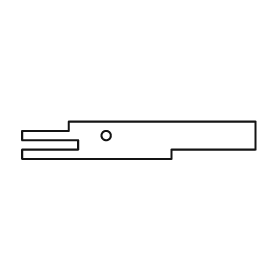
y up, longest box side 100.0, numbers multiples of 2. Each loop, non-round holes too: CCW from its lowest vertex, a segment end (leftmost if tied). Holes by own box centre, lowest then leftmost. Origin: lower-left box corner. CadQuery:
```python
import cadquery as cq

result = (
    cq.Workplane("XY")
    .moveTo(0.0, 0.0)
    .lineTo(64.0, 0.0)
    .lineTo(64.0, 4.0)
    .lineTo(100.0, 4.0)
    .lineTo(100.0, 16.0)
    .lineTo(20.0, 16.0)
    .lineTo(20.0, 12.0)
    .lineTo(0.0, 12.0)
    .lineTo(0.0, 8.0)
    .lineTo(24.0, 8.0)
    .lineTo(24.0, 4.0)
    .lineTo(0.0, 4.0)
    .close()
    .moveTo(36.0, 10.0)
    .circle(2.0)
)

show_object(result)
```